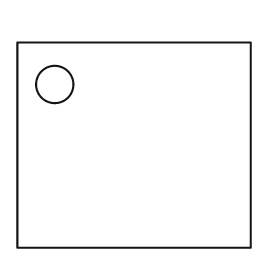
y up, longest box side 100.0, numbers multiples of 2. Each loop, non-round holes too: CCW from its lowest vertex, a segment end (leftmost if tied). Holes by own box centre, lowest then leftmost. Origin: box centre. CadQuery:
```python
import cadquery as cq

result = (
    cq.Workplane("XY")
    .moveTo(-50.0, -44.0)
    .lineTo(50.0, -44.0)
    .lineTo(50.0, 44.0)
    .lineTo(-50.0, 44.0)
    .close()
    .moveTo(-34.0, 26.0)
    .circle(8.0)
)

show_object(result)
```